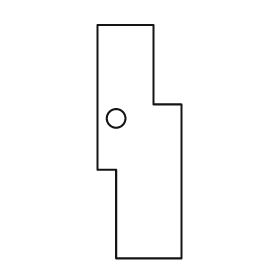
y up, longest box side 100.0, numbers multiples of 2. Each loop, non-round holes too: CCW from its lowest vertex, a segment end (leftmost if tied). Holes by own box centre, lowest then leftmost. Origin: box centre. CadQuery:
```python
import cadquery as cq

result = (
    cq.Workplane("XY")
    .moveTo(-10.0, -50.0)
    .lineTo(18.0, -50.0)
    .lineTo(18.0, 16.0)
    .lineTo(6.0, 16.0)
    .lineTo(6.0, 50.0)
    .lineTo(-18.0, 50.0)
    .lineTo(-18.0, -12.0)
    .lineTo(-10.0, -12.0)
    .close()
    .moveTo(-10.0, 10.0)
    .circle(4.0)
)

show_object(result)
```